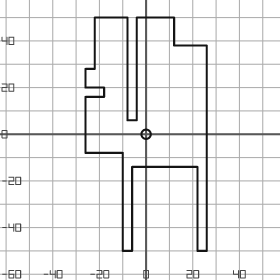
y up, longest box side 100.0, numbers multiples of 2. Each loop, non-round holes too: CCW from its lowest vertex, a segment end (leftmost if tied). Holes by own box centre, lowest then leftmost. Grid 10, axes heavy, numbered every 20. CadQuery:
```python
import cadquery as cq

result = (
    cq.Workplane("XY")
    .moveTo(-10.0, -50.0)
    .lineTo(-6.0, -50.0)
    .lineTo(-6.0, -14.0)
    .lineTo(22.0, -14.0)
    .lineTo(22.0, -50.0)
    .lineTo(26.0, -50.0)
    .lineTo(26.0, 38.0)
    .lineTo(12.0, 38.0)
    .lineTo(12.0, 50.0)
    .lineTo(-4.0, 50.0)
    .lineTo(-4.0, 6.0)
    .lineTo(-8.0, 6.0)
    .lineTo(-8.0, 50.0)
    .lineTo(-22.0, 50.0)
    .lineTo(-22.0, 28.0)
    .lineTo(-26.0, 28.0)
    .lineTo(-26.0, 20.0)
    .lineTo(-18.0, 20.0)
    .lineTo(-18.0, 16.0)
    .lineTo(-26.0, 16.0)
    .lineTo(-26.0, -8.0)
    .lineTo(-10.0, -8.0)
    .close()
    .moveTo(0.0, 0.0)
    .circle(2.0)
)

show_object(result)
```